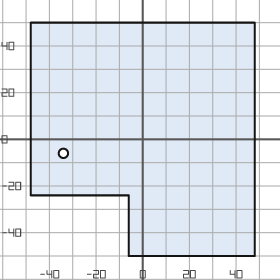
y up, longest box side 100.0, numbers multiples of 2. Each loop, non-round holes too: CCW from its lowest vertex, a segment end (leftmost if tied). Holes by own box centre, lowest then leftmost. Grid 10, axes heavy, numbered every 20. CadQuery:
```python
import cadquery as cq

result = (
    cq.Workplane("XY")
    .moveTo(-6.0, -50.0)
    .lineTo(48.0, -50.0)
    .lineTo(48.0, 50.0)
    .lineTo(-48.0, 50.0)
    .lineTo(-48.0, -24.0)
    .lineTo(-6.0, -24.0)
    .close()
    .moveTo(-34.0, -6.0)
    .circle(2.0)
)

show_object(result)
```